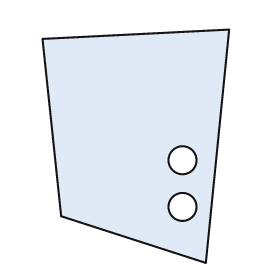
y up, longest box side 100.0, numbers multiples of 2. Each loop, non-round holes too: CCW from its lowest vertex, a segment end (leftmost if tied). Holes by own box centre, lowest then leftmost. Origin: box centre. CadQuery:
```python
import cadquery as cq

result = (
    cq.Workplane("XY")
    .moveTo(30.0, -50.0)
    .lineTo(40.0, 50.0)
    .lineTo(-40.0, 46.0)
    .lineTo(-32.0, -30.0)
    .close()
    .moveTo(20.0, -26.0)
    .circle(6.0)
    .moveTo(20.0, -6.0)
    .circle(6.0)
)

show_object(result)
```